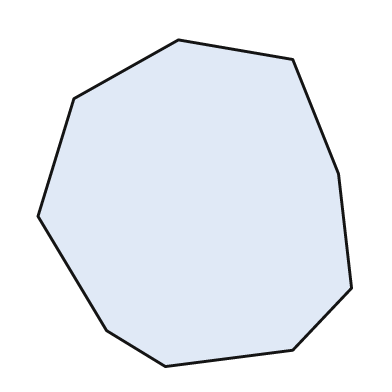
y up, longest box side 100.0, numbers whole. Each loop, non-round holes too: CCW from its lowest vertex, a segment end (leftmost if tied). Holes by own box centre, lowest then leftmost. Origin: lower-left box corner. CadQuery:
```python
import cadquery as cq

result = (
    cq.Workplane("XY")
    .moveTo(39.0, 0.0)
    .lineTo(78.0, 5.0)
    .lineTo(96.0, 24.0)
    .lineTo(92.0, 59.0)
    .lineTo(78.0, 94.0)
    .lineTo(43.0, 100.0)
    .lineTo(11.0, 82.0)
    .lineTo(0.0, 46.0)
    .lineTo(21.0, 11.0)
    .close()
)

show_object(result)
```